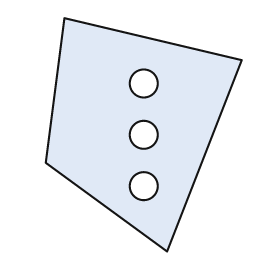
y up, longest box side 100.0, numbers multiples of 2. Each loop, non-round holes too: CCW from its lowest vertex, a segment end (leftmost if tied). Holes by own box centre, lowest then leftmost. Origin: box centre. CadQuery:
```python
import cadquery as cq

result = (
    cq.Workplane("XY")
    .moveTo(10.0, -50.0)
    .lineTo(42.0, 32.0)
    .lineTo(-34.0, 50.0)
    .lineTo(-42.0, -12.0)
    .close()
    .moveTo(0.0, -22.0)
    .circle(6.0)
    .moveTo(0.0, 0.0)
    .circle(6.0)
    .moveTo(0.0, 22.0)
    .circle(6.0)
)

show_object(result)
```